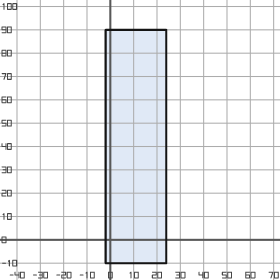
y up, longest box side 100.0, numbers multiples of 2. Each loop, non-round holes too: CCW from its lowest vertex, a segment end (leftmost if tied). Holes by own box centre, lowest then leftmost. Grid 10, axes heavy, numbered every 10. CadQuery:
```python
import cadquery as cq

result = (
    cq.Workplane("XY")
    .moveTo(-2.0, -10.0)
    .lineTo(24.0, -10.0)
    .lineTo(24.0, 90.0)
    .lineTo(-2.0, 90.0)
    .close()
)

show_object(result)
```